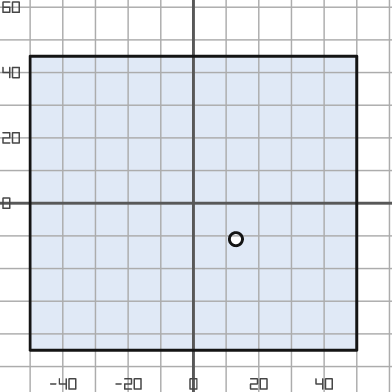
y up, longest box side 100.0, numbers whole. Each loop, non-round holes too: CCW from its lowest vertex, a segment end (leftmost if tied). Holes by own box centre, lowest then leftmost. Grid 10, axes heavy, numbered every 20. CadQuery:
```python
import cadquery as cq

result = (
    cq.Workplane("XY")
    .moveTo(-50.0, -45.0)
    .lineTo(50.0, -45.0)
    .lineTo(50.0, 45.0)
    .lineTo(-50.0, 45.0)
    .close()
    .moveTo(13.0, -11.0)
    .circle(2.0)
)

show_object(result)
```